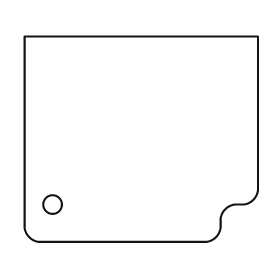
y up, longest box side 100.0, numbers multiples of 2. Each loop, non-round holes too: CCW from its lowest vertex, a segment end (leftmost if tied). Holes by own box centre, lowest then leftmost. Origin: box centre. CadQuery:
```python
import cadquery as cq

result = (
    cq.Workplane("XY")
    .moveTo(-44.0, -44.0)
    .lineTo(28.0, -44.0)
    .threePointArc((32.0, -42.0), (34.0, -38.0))
    .lineTo(34.0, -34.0)
    .threePointArc((36.0, -30.0), (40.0, -28.0))
    .lineTo(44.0, -28.0)
    .threePointArc((48.0, -26.0), (50.0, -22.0))
    .lineTo(50.0, 44.0)
    .lineTo(-50.0, 44.0)
    .lineTo(-50.0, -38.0)
    .threePointArc((-48.0, -42.0), (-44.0, -44.0))
    .close()
    .moveTo(-38.0, -28.0)
    .circle(4.0)
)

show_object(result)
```